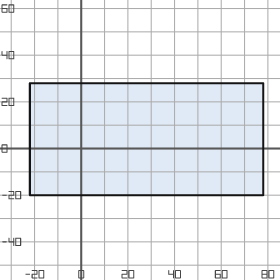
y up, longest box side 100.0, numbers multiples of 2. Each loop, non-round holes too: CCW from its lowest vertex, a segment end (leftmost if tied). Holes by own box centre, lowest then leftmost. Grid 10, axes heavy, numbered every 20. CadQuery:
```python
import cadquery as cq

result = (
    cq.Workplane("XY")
    .moveTo(-22.0, -20.0)
    .lineTo(78.0, -20.0)
    .lineTo(78.0, 28.0)
    .lineTo(-22.0, 28.0)
    .close()
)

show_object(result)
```